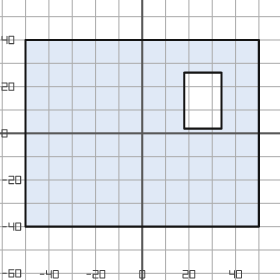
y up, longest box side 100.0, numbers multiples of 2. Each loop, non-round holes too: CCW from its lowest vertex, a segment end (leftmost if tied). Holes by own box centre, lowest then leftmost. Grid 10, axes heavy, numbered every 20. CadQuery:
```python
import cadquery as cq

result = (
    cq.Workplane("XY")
    .moveTo(-50.0, -40.0)
    .lineTo(50.0, -40.0)
    .lineTo(50.0, 40.0)
    .lineTo(-50.0, 40.0)
    .close()
    .moveTo(18.0, 2.0)
    .lineTo(34.0, 2.0)
    .lineTo(34.0, 26.0)
    .lineTo(18.0, 26.0)
    .close()
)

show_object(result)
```